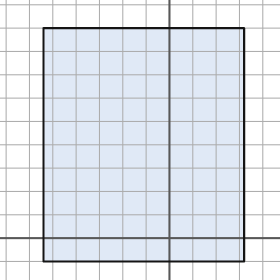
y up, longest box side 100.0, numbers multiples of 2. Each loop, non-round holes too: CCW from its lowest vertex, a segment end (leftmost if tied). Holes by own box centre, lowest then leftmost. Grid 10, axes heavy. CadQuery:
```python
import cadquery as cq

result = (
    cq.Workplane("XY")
    .moveTo(-54.0, -10.0)
    .lineTo(32.0, -10.0)
    .lineTo(32.0, 90.0)
    .lineTo(-54.0, 90.0)
    .close()
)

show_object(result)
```